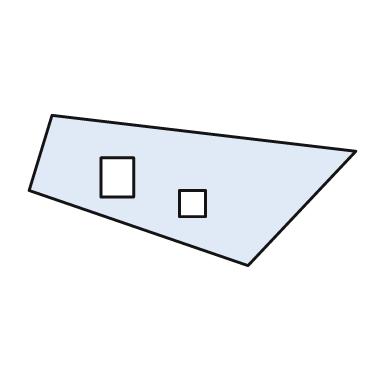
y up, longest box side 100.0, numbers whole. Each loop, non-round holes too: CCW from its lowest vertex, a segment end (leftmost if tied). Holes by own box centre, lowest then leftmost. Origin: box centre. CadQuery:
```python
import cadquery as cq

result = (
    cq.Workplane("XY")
    .moveTo(17.0, -23.0)
    .lineTo(50.0, 12.0)
    .lineTo(-43.0, 23.0)
    .lineTo(-50.0, 0.0)
    .close()
    .moveTo(-4.0, -8.0)
    .lineTo(4.0, -8.0)
    .lineTo(4.0, 0.0)
    .lineTo(-4.0, 0.0)
    .close()
    .moveTo(-28.0, -2.0)
    .lineTo(-18.0, -2.0)
    .lineTo(-18.0, 10.0)
    .lineTo(-28.0, 10.0)
    .close()
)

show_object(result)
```